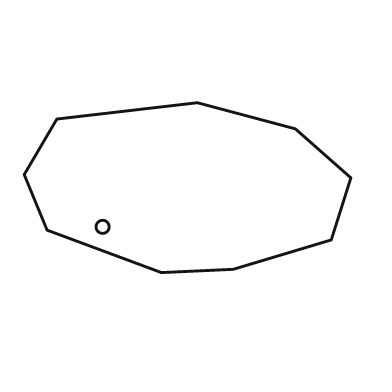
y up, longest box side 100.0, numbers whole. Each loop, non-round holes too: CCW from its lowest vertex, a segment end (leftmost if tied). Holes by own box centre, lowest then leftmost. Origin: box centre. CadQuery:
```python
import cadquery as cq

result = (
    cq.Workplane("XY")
    .moveTo(-8.0, -26.0)
    .lineTo(14.0, -25.0)
    .lineTo(44.0, -16.0)
    .lineTo(50.0, 3.0)
    .lineTo(33.0, 18.0)
    .lineTo(3.0, 26.0)
    .lineTo(-40.0, 21.0)
    .lineTo(-50.0, 4.0)
    .lineTo(-43.0, -13.0)
    .close()
    .moveTo(-26.0, -12.0)
    .circle(2.0)
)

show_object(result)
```